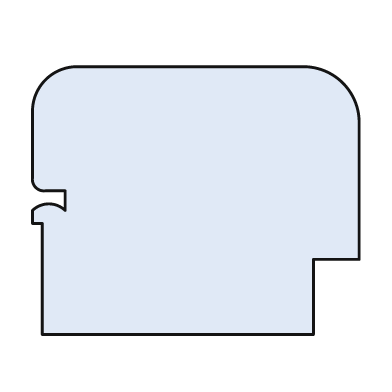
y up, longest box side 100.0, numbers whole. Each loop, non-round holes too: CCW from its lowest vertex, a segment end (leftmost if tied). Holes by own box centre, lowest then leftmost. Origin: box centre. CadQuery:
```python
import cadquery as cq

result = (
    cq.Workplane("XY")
    .moveTo(-47.0, -41.0)
    .lineTo(36.0, -41.0)
    .lineTo(36.0, -18.0)
    .lineTo(50.0, -18.0)
    .lineTo(50.0, 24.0)
    .threePointArc((45.0, 36.0), (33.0, 41.0))
    .lineTo(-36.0, 41.0)
    .threePointArc((-46.0, 37.0), (-50.0, 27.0))
    .lineTo(-50.0, 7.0)
    .threePointArc((-49.0, 4.0), (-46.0, 3.0))
    .lineTo(-40.0, 3.0)
    .lineTo(-40.0, -3.0)
    .threePointArc((-45.0, -1.0), (-50.0, -3.0))
    .lineTo(-50.0, -7.0)
    .lineTo(-47.0, -7.0)
    .close()
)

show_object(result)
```